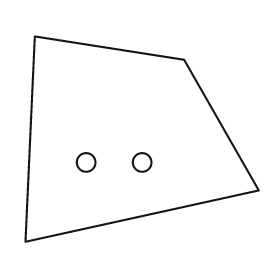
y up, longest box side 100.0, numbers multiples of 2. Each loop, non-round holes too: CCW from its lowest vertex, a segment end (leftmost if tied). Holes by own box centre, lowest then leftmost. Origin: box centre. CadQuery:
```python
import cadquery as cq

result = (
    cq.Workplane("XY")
    .moveTo(-50.0, -44.0)
    .lineTo(50.0, -22.0)
    .lineTo(18.0, 34.0)
    .lineTo(-46.0, 44.0)
    .close()
    .moveTo(-24.0, -10.0)
    .circle(4.0)
    .moveTo(0.0, -10.0)
    .circle(4.0)
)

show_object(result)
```